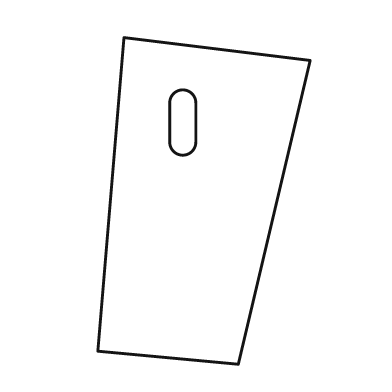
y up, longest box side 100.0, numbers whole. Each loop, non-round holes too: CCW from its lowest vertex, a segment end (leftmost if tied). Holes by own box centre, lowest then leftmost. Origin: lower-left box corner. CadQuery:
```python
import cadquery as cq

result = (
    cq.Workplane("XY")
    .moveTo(43.0, 0.0)
    .lineTo(65.0, 93.0)
    .lineTo(8.0, 100.0)
    .lineTo(0.0, 4.0)
    .close()
    .moveTo(22.0, 68.0)
    .threePointArc((26.0, 64.0), (30.0, 68.0))
    .lineTo(30.0, 80.0)
    .threePointArc((26.0, 84.0), (22.0, 80.0))
    .close()
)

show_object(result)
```